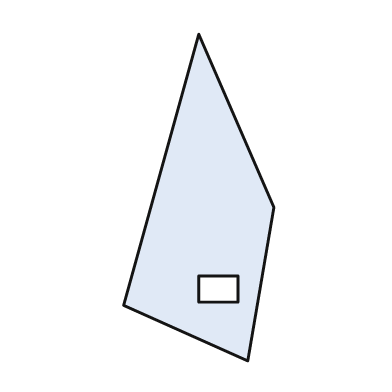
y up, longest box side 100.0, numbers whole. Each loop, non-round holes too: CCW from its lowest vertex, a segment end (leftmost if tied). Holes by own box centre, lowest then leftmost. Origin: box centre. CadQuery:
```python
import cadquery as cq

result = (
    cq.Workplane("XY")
    .moveTo(15.0, -50.0)
    .lineTo(23.0, -3.0)
    .lineTo(0.0, 50.0)
    .lineTo(-23.0, -33.0)
    .close()
    .moveTo(0.0, -32.0)
    .lineTo(12.0, -32.0)
    .lineTo(12.0, -24.0)
    .lineTo(0.0, -24.0)
    .close()
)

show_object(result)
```